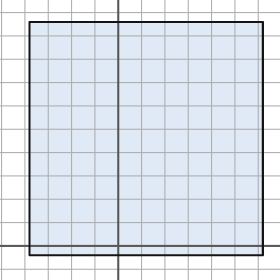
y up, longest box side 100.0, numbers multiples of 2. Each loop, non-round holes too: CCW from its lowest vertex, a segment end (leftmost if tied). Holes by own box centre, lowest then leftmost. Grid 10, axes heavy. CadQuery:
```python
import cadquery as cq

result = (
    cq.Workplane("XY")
    .moveTo(-38.0, -4.0)
    .lineTo(62.0, -4.0)
    .lineTo(62.0, 96.0)
    .lineTo(-38.0, 96.0)
    .close()
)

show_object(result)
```